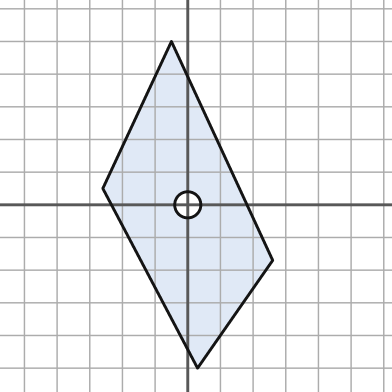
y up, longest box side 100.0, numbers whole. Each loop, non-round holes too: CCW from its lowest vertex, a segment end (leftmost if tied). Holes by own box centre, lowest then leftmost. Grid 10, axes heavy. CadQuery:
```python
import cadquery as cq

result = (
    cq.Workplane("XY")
    .moveTo(3.0, -50.0)
    .lineTo(26.0, -17.0)
    .lineTo(-5.0, 50.0)
    .lineTo(-26.0, 5.0)
    .close()
    .moveTo(0.0, 0.0)
    .circle(4.0)
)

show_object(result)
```